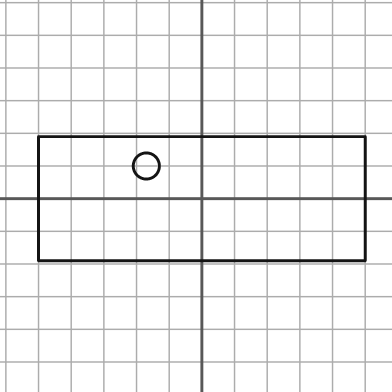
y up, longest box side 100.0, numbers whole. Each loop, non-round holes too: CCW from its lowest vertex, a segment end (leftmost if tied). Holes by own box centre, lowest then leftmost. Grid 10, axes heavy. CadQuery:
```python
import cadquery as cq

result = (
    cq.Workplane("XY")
    .moveTo(-50.0, -19.0)
    .lineTo(50.0, -19.0)
    .lineTo(50.0, 19.0)
    .lineTo(-50.0, 19.0)
    .close()
    .moveTo(-17.0, 10.0)
    .circle(4.0)
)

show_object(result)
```